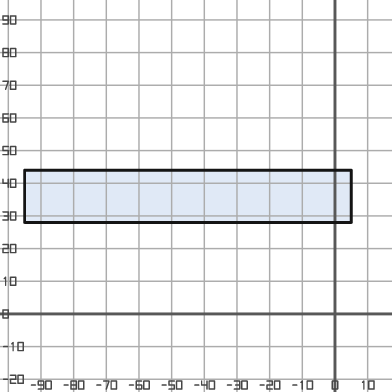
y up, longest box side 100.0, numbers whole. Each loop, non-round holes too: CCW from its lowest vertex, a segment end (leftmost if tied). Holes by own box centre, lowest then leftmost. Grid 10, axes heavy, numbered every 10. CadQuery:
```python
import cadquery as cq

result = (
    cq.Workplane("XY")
    .moveTo(-95.0, 28.0)
    .lineTo(5.0, 28.0)
    .lineTo(5.0, 44.0)
    .lineTo(-95.0, 44.0)
    .close()
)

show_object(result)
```